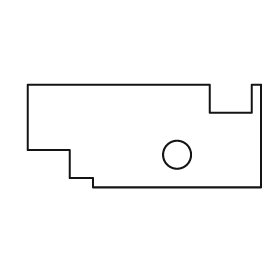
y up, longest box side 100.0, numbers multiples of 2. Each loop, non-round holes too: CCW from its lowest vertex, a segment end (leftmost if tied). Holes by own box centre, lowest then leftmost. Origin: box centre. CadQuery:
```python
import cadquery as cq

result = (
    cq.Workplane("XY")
    .moveTo(-22.0, -22.0)
    .lineTo(50.0, -22.0)
    .lineTo(50.0, 22.0)
    .lineTo(46.0, 22.0)
    .lineTo(46.0, 10.0)
    .lineTo(28.0, 10.0)
    .lineTo(28.0, 22.0)
    .lineTo(-50.0, 22.0)
    .lineTo(-50.0, -6.0)
    .lineTo(-32.0, -6.0)
    .lineTo(-32.0, -18.0)
    .lineTo(-22.0, -18.0)
    .close()
    .moveTo(14.0, -8.0)
    .circle(6.0)
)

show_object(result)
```